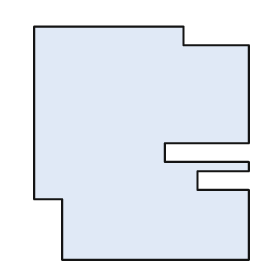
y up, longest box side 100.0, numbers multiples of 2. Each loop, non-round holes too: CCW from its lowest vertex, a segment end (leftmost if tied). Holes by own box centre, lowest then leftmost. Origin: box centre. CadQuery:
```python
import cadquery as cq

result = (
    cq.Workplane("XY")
    .moveTo(-34.0, -50.0)
    .lineTo(46.0, -50.0)
    .lineTo(46.0, -20.0)
    .lineTo(24.0, -20.0)
    .lineTo(24.0, -12.0)
    .lineTo(46.0, -12.0)
    .lineTo(46.0, -8.0)
    .lineTo(10.0, -8.0)
    .lineTo(10.0, 0.0)
    .lineTo(46.0, 0.0)
    .lineTo(46.0, 42.0)
    .lineTo(18.0, 42.0)
    .lineTo(18.0, 50.0)
    .lineTo(-46.0, 50.0)
    .lineTo(-46.0, -24.0)
    .lineTo(-34.0, -24.0)
    .close()
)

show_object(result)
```